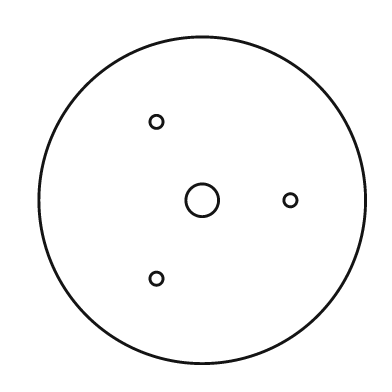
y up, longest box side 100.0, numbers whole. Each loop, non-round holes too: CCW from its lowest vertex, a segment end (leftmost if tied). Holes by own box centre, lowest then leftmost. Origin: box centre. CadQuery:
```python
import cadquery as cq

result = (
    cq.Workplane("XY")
    .moveTo(0.0, 0.0)
    .circle(50.0)
    .moveTo(-14.0, -24.0)
    .circle(2.0)
    .moveTo(0.0, 0.0)
    .circle(5.0)
    .moveTo(27.0, 0.0)
    .circle(2.0)
    .moveTo(-14.0, 24.0)
    .circle(2.0)
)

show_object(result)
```